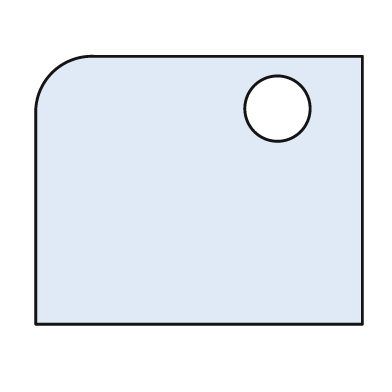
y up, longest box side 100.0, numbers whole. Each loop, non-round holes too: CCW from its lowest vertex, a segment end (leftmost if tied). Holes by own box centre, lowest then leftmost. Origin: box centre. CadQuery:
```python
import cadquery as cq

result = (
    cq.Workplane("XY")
    .moveTo(-50.0, -41.0)
    .lineTo(50.0, -41.0)
    .lineTo(50.0, 41.0)
    .lineTo(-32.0, 41.0)
    .threePointArc((-45.0, 36.0), (-50.0, 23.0))
    .close()
    .moveTo(24.0, 25.0)
    .circle(10.0)
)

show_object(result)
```